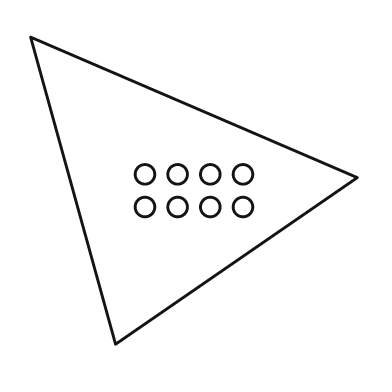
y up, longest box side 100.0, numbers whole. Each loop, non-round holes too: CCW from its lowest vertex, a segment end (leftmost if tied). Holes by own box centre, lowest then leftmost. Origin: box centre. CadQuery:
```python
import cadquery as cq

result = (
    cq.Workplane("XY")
    .moveTo(-24.0, -47.0)
    .lineTo(50.0, 4.0)
    .lineTo(-50.0, 47.0)
    .close()
    .moveTo(-15.0, -5.0)
    .circle(3.0)
    .moveTo(-5.0, -5.0)
    .circle(3.0)
    .moveTo(5.0, -5.0)
    .circle(3.0)
    .moveTo(15.0, -5.0)
    .circle(3.0)
    .moveTo(-15.0, 5.0)
    .circle(3.0)
    .moveTo(-5.0, 5.0)
    .circle(3.0)
    .moveTo(5.0, 5.0)
    .circle(3.0)
    .moveTo(15.0, 5.0)
    .circle(3.0)
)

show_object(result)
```